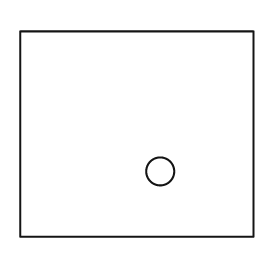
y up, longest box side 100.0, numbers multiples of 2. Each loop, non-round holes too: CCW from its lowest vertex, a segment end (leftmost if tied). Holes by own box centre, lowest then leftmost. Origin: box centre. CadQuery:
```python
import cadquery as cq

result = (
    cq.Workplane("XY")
    .moveTo(-50.0, -44.0)
    .lineTo(50.0, -44.0)
    .lineTo(50.0, 44.0)
    .lineTo(-50.0, 44.0)
    .close()
    .moveTo(10.0, -16.0)
    .circle(6.0)
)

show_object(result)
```